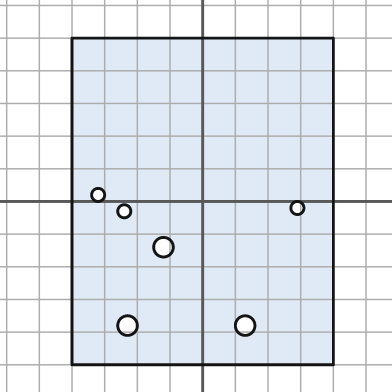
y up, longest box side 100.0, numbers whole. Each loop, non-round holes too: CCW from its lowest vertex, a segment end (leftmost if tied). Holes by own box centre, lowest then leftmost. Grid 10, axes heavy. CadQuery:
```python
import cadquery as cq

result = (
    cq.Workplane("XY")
    .moveTo(-40.0, -50.0)
    .lineTo(40.0, -50.0)
    .lineTo(40.0, 50.0)
    .lineTo(-40.0, 50.0)
    .close()
    .moveTo(-23.0, -38.0)
    .circle(3.0)
    .moveTo(13.0, -38.0)
    .circle(3.0)
    .moveTo(-12.0, -14.0)
    .circle(3.0)
    .moveTo(-24.0, -3.0)
    .circle(2.0)
    .moveTo(29.0, -2.0)
    .circle(2.0)
    .moveTo(-32.0, 2.0)
    .circle(2.0)
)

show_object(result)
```